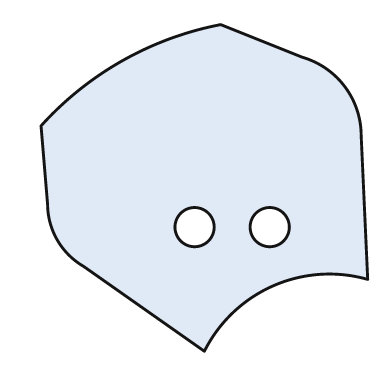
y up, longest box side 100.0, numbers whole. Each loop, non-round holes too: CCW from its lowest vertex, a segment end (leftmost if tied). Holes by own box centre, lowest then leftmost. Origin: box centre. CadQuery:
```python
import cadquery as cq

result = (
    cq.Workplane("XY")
    .moveTo(0.0, -50.0)
    .threePointArc((21.0, -30.0), (50.0, -28.0))
    .lineTo(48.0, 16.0)
    .threePointArc((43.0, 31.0), (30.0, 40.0))
    .lineTo(5.0, 50.0)
    .threePointArc((-25.0, 39.0), (-50.0, 19.0))
    .lineTo(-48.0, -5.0)
    .threePointArc((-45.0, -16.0), (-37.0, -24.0))
    .close()
    .moveTo(-3.0, -12.0)
    .circle(6.0)
    .moveTo(20.0, -12.0)
    .circle(6.0)
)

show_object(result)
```